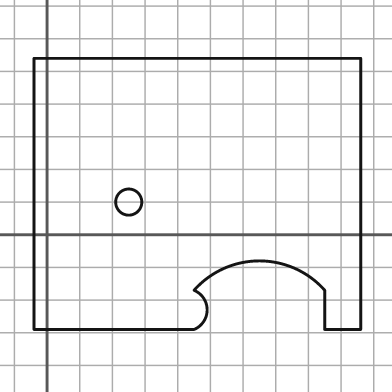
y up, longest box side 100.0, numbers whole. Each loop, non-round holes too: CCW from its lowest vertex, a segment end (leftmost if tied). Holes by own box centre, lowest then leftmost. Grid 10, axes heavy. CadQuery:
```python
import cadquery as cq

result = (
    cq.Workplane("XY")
    .moveTo(-4.0, -29.0)
    .lineTo(45.0, -29.0)
    .threePointArc((49.0, -23.0), (45.0, -17.0))
    .threePointArc((65.0, -8.0), (85.0, -17.0))
    .lineTo(85.0, -29.0)
    .lineTo(96.0, -29.0)
    .lineTo(96.0, 54.0)
    .lineTo(-4.0, 54.0)
    .close()
    .moveTo(25.0, 10.0)
    .circle(4.0)
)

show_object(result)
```